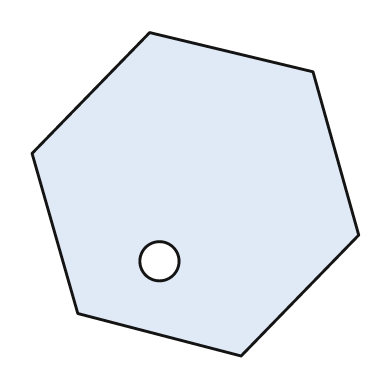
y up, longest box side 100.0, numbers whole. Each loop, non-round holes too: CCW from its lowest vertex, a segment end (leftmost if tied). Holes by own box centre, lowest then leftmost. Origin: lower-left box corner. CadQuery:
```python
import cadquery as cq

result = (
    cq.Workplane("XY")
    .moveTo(64.0, 0.0)
    .lineTo(100.0, 37.0)
    .lineTo(86.0, 87.0)
    .lineTo(36.0, 99.0)
    .lineTo(0.0, 62.0)
    .lineTo(14.0, 13.0)
    .close()
    .moveTo(39.0, 29.0)
    .circle(6.0)
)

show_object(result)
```